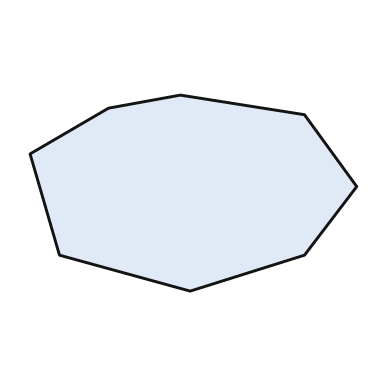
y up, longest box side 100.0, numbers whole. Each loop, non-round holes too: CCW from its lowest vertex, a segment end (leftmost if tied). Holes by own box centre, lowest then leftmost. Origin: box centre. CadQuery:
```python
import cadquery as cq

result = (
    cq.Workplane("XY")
    .moveTo(-1.0, -30.0)
    .lineTo(34.0, -19.0)
    .lineTo(50.0, 2.0)
    .lineTo(34.0, 24.0)
    .lineTo(-4.0, 30.0)
    .lineTo(-26.0, 26.0)
    .lineTo(-50.0, 12.0)
    .lineTo(-41.0, -19.0)
    .close()
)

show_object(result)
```